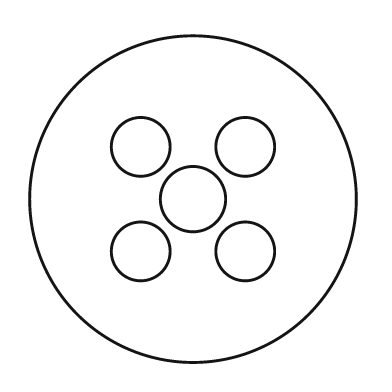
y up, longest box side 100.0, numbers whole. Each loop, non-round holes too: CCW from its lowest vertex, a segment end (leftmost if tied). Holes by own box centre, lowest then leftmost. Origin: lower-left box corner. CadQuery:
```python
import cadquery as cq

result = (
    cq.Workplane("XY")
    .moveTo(50.0, 50.0)
    .circle(50.0)
    .moveTo(34.0, 34.0)
    .circle(9.0)
    .moveTo(66.0, 34.0)
    .circle(9.0)
    .moveTo(50.0, 50.0)
    .circle(10.0)
    .moveTo(34.0, 66.0)
    .circle(9.0)
    .moveTo(66.0, 66.0)
    .circle(9.0)
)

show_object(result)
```